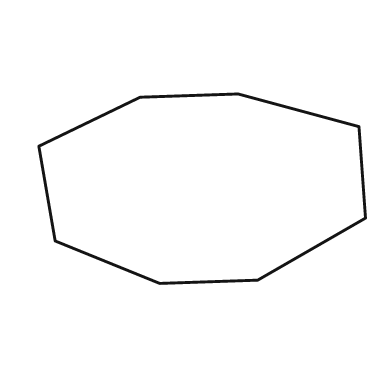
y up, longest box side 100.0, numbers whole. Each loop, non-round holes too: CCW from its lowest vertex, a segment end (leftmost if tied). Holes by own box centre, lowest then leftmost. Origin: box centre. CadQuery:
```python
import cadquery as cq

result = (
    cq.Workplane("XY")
    .moveTo(-13.0, -29.0)
    .lineTo(17.0, -28.0)
    .lineTo(50.0, -9.0)
    .lineTo(48.0, 19.0)
    .lineTo(11.0, 29.0)
    .lineTo(-19.0, 28.0)
    .lineTo(-50.0, 13.0)
    .lineTo(-45.0, -16.0)
    .close()
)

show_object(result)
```